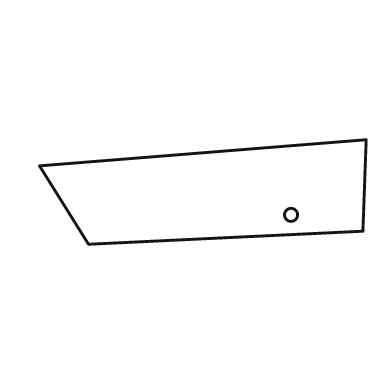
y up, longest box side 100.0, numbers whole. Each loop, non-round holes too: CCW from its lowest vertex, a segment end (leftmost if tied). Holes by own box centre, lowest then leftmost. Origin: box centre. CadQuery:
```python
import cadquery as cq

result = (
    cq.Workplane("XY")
    .moveTo(-35.0, -16.0)
    .lineTo(49.0, -12.0)
    .lineTo(50.0, 16.0)
    .lineTo(-50.0, 8.0)
    .close()
    .moveTo(27.0, -7.0)
    .circle(2.0)
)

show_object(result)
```